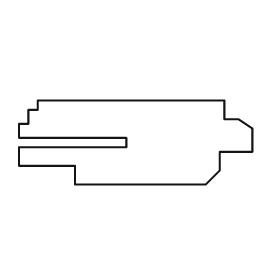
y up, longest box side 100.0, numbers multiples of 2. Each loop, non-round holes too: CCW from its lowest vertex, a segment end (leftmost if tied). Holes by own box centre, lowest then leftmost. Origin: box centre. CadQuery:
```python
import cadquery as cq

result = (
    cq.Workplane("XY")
    .moveTo(-26.0, -18.0)
    .lineTo(30.0, -18.0)
    .lineTo(36.0, -12.0)
    .lineTo(36.0, -4.0)
    .lineTo(50.0, -4.0)
    .lineTo(50.0, 6.0)
    .lineTo(44.0, 10.0)
    .lineTo(38.0, 10.0)
    .lineTo(38.0, 18.0)
    .lineTo(-42.0, 18.0)
    .lineTo(-42.0, 14.0)
    .lineTo(-46.0, 14.0)
    .lineTo(-46.0, 8.0)
    .lineTo(-50.0, 8.0)
    .lineTo(-50.0, 2.0)
    .lineTo(-4.0, 2.0)
    .lineTo(-4.0, -2.0)
    .lineTo(-50.0, -2.0)
    .lineTo(-50.0, -10.0)
    .lineTo(-26.0, -10.0)
    .close()
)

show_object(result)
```